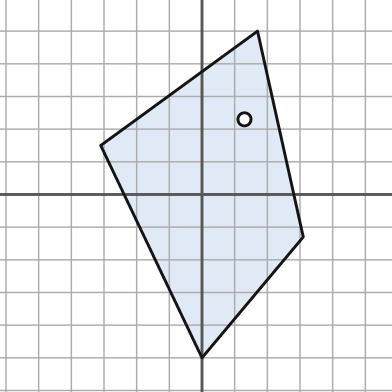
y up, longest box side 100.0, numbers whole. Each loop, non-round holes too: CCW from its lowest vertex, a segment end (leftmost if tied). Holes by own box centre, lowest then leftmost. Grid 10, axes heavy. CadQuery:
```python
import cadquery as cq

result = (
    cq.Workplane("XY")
    .moveTo(0.0, -50.0)
    .lineTo(31.0, -13.0)
    .lineTo(17.0, 50.0)
    .lineTo(-31.0, 15.0)
    .close()
    .moveTo(13.0, 23.0)
    .circle(2.0)
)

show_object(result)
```